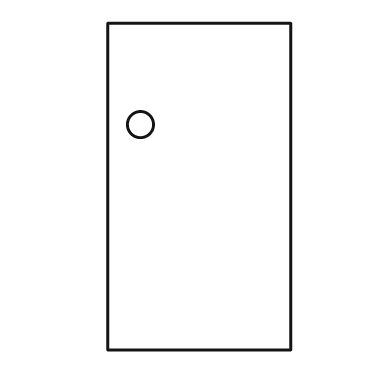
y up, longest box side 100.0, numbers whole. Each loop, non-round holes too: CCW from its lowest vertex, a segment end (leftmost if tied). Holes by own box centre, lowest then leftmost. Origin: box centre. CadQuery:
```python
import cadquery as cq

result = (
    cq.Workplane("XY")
    .moveTo(-28.0, -50.0)
    .lineTo(28.0, -50.0)
    .lineTo(28.0, 50.0)
    .lineTo(-28.0, 50.0)
    .close()
    .moveTo(-18.0, 19.0)
    .circle(4.0)
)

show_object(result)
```